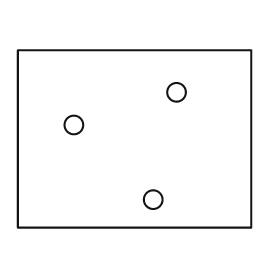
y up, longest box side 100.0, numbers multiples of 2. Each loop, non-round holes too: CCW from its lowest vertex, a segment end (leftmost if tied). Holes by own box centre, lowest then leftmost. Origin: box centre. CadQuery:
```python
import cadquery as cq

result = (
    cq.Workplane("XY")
    .moveTo(-50.0, -38.0)
    .lineTo(50.0, -38.0)
    .lineTo(50.0, 38.0)
    .lineTo(-50.0, 38.0)
    .close()
    .moveTo(8.0, -26.0)
    .circle(4.0)
    .moveTo(-26.0, 6.0)
    .circle(4.0)
    .moveTo(18.0, 20.0)
    .circle(4.0)
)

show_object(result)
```